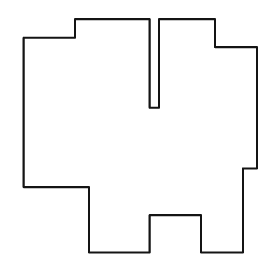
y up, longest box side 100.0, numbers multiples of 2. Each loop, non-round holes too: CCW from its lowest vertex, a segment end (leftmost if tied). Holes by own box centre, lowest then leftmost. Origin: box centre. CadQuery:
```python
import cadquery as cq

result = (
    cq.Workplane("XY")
    .moveTo(-22.0, -50.0)
    .lineTo(4.0, -50.0)
    .lineTo(4.0, -34.0)
    .lineTo(26.0, -34.0)
    .lineTo(26.0, -50.0)
    .lineTo(44.0, -50.0)
    .lineTo(44.0, -14.0)
    .lineTo(50.0, -14.0)
    .lineTo(50.0, 38.0)
    .lineTo(32.0, 38.0)
    .lineTo(32.0, 50.0)
    .lineTo(8.0, 50.0)
    .lineTo(8.0, 12.0)
    .lineTo(4.0, 12.0)
    .lineTo(4.0, 50.0)
    .lineTo(-28.0, 50.0)
    .lineTo(-28.0, 42.0)
    .lineTo(-50.0, 42.0)
    .lineTo(-50.0, -22.0)
    .lineTo(-22.0, -22.0)
    .close()
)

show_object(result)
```